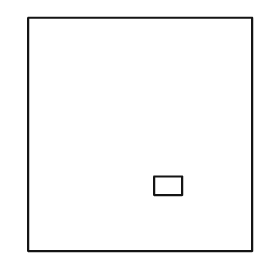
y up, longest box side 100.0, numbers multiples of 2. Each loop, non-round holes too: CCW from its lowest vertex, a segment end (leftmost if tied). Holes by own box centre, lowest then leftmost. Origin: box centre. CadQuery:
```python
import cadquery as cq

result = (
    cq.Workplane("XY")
    .moveTo(-48.0, -50.0)
    .lineTo(48.0, -50.0)
    .lineTo(48.0, 50.0)
    .lineTo(-48.0, 50.0)
    .close()
    .moveTo(6.0, -26.0)
    .lineTo(18.0, -26.0)
    .lineTo(18.0, -18.0)
    .lineTo(6.0, -18.0)
    .close()
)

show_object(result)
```